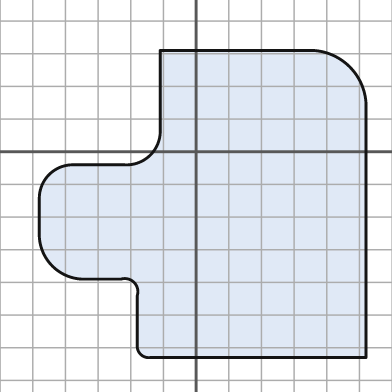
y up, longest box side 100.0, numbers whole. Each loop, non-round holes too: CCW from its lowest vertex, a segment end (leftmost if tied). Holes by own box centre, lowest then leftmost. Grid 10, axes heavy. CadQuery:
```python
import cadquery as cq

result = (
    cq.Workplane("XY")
    .moveTo(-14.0, -63.0)
    .lineTo(52.0, -63.0)
    .lineTo(52.0, 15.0)
    .threePointArc((47.0, 26.0), (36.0, 31.0))
    .lineTo(-11.0, 31.0)
    .lineTo(-11.0, 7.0)
    .threePointArc((-14.0, -1.0), (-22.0, -4.0))
    .lineTo(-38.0, -4.0)
    .threePointArc((-45.0, -7.0), (-48.0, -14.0))
    .lineTo(-48.0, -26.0)
    .threePointArc((-44.0, -35.0), (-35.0, -39.0))
    .lineTo(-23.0, -39.0)
    .threePointArc((-19.0, -40.0), (-18.0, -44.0))
    .lineTo(-18.0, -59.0)
    .threePointArc((-17.0, -62.0), (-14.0, -63.0))
    .close()
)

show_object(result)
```